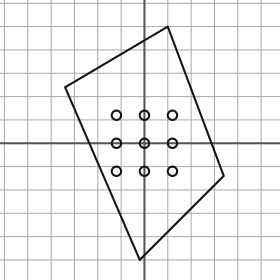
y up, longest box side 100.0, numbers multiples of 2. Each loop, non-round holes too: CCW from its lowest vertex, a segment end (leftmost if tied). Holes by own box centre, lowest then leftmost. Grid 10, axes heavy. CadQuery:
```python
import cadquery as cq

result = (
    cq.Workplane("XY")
    .moveTo(-2.0, -50.0)
    .lineTo(34.0, -14.0)
    .lineTo(10.0, 50.0)
    .lineTo(-34.0, 24.0)
    .close()
    .moveTo(-12.0, -12.0)
    .circle(2.0)
    .moveTo(0.0, -12.0)
    .circle(2.0)
    .moveTo(12.0, -12.0)
    .circle(2.0)
    .moveTo(-12.0, 0.0)
    .circle(2.0)
    .moveTo(0.0, 0.0)
    .circle(2.0)
    .moveTo(12.0, 0.0)
    .circle(2.0)
    .moveTo(-12.0, 12.0)
    .circle(2.0)
    .moveTo(0.0, 12.0)
    .circle(2.0)
    .moveTo(12.0, 12.0)
    .circle(2.0)
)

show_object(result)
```